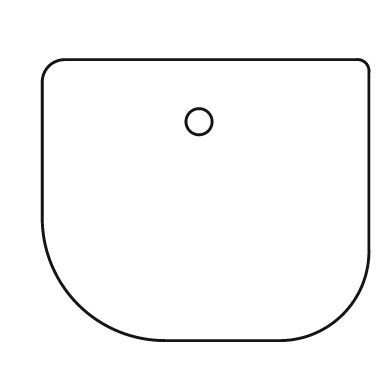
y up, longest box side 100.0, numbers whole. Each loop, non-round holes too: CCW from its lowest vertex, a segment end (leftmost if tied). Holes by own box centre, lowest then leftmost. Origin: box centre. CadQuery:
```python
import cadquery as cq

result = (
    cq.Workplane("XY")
    .moveTo(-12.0, -43.0)
    .lineTo(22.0, -43.0)
    .threePointArc((42.0, -35.0), (50.0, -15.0))
    .lineTo(50.0, 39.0)
    .threePointArc((49.0, 42.0), (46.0, 43.0))
    .lineTo(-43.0, 43.0)
    .threePointArc((-48.0, 41.0), (-50.0, 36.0))
    .lineTo(-50.0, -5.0)
    .threePointArc((-39.0, -32.0), (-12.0, -43.0))
    .close()
    .moveTo(-2.0, 24.0)
    .circle(4.0)
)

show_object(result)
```